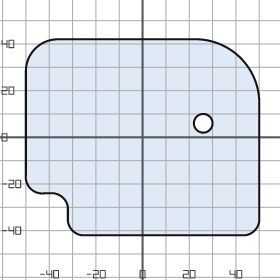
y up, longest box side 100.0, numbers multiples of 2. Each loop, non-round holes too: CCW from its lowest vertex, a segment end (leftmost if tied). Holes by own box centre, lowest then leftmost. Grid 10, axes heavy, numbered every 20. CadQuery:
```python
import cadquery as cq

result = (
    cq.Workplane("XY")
    .moveTo(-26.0, -42.0)
    .lineTo(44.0, -42.0)
    .threePointArc((48.0, -40.0), (50.0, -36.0))
    .lineTo(50.0, 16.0)
    .threePointArc((42.0, 34.0), (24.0, 42.0))
    .lineTo(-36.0, 42.0)
    .threePointArc((-46.0, 38.0), (-50.0, 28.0))
    .lineTo(-50.0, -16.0)
    .threePointArc((-48.0, -22.0), (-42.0, -24.0))
    .lineTo(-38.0, -24.0)
    .threePointArc((-34.0, -26.0), (-32.0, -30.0))
    .lineTo(-32.0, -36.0)
    .threePointArc((-30.0, -40.0), (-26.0, -42.0))
    .close()
    .moveTo(26.0, 6.0)
    .circle(4.0)
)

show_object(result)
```